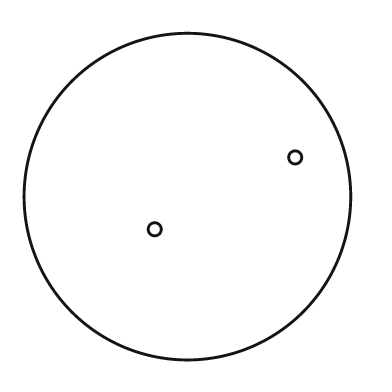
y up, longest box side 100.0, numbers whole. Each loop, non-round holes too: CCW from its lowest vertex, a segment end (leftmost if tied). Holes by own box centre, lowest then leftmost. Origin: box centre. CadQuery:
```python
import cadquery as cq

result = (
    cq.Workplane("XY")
    .moveTo(0.0, 0.0)
    .circle(50.0)
    .moveTo(-10.0, -10.0)
    .circle(2.0)
    .moveTo(33.0, 12.0)
    .circle(2.0)
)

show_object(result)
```